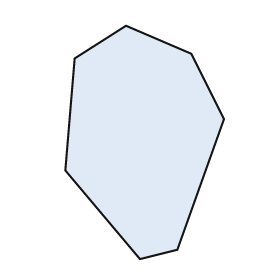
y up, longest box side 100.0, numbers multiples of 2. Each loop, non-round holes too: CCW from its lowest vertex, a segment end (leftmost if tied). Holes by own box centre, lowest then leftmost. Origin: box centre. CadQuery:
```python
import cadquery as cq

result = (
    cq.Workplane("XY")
    .moveTo(-2.0, -50.0)
    .lineTo(14.0, -46.0)
    .lineTo(34.0, 10.0)
    .lineTo(20.0, 38.0)
    .lineTo(-8.0, 50.0)
    .lineTo(-30.0, 36.0)
    .lineTo(-34.0, -12.0)
    .close()
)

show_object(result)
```